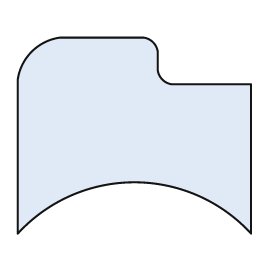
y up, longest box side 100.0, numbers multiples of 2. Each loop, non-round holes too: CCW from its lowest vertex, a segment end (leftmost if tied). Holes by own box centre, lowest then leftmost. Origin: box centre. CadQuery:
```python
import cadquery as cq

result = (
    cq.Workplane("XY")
    .moveTo(-50.0, -42.0)
    .threePointArc((0.0, -20.0), (50.0, -42.0))
    .lineTo(50.0, 22.0)
    .lineTo(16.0, 22.0)
    .threePointArc((12.0, 24.0), (10.0, 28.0))
    .lineTo(10.0, 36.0)
    .threePointArc((8.0, 40.0), (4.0, 42.0))
    .lineTo(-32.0, 42.0)
    .threePointArc((-44.0, 36.0), (-50.0, 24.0))
    .close()
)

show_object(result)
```